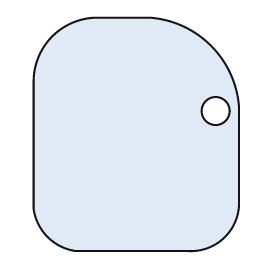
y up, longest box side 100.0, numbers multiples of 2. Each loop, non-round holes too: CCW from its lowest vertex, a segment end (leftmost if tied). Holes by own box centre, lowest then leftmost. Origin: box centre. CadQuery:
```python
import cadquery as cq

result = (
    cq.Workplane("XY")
    .moveTo(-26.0, -50.0)
    .lineTo(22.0, -50.0)
    .threePointArc((38.0, -44.0), (44.0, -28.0))
    .lineTo(44.0, 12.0)
    .threePointArc((32.0, 38.0), (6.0, 50.0))
    .lineTo(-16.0, 50.0)
    .threePointArc((-36.0, 42.0), (-44.0, 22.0))
    .lineTo(-44.0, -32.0)
    .threePointArc((-38.0, -44.0), (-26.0, -50.0))
    .close()
    .moveTo(34.0, 10.0)
    .circle(6.0)
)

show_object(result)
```